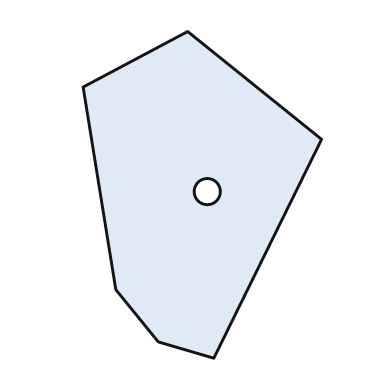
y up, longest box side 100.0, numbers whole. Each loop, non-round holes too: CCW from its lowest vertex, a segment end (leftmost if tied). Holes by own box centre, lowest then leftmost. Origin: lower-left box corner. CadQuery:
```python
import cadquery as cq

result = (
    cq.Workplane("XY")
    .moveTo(40.0, 0.0)
    .lineTo(73.0, 67.0)
    .lineTo(32.0, 100.0)
    .lineTo(0.0, 83.0)
    .lineTo(10.0, 21.0)
    .lineTo(23.0, 5.0)
    .close()
    .moveTo(38.0, 51.0)
    .circle(4.0)
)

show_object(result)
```